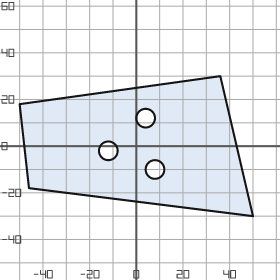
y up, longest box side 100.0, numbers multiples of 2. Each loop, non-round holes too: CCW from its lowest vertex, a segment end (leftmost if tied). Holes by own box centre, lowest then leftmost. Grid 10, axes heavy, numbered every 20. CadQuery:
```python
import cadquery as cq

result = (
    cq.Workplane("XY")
    .moveTo(50.0, -30.0)
    .lineTo(36.0, 30.0)
    .lineTo(-50.0, 18.0)
    .lineTo(-46.0, -18.0)
    .close()
    .moveTo(8.0, -10.0)
    .circle(4.0)
    .moveTo(-12.0, -2.0)
    .circle(4.0)
    .moveTo(4.0, 12.0)
    .circle(4.0)
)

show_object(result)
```